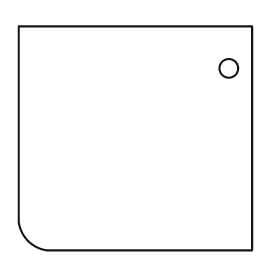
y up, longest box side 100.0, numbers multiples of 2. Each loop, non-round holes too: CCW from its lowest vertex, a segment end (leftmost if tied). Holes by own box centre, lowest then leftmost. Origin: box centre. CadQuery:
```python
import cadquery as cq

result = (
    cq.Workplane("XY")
    .moveTo(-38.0, -48.0)
    .lineTo(50.0, -48.0)
    .lineTo(50.0, 48.0)
    .lineTo(-50.0, 48.0)
    .lineTo(-50.0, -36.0)
    .threePointArc((-46.0, -44.0), (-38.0, -48.0))
    .close()
    .moveTo(40.0, 30.0)
    .circle(4.0)
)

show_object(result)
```